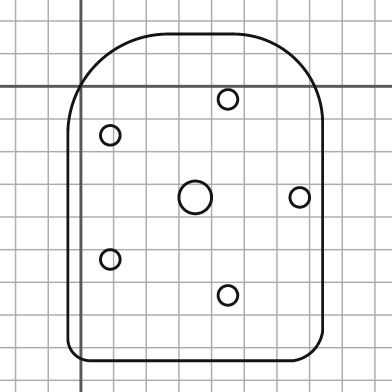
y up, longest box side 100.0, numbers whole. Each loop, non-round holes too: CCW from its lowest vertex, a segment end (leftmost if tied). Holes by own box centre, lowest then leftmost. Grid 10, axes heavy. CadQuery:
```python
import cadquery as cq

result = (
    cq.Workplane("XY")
    .moveTo(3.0, -84.0)
    .lineTo(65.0, -84.0)
    .threePointArc((71.0, -81.0), (74.0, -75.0))
    .lineTo(74.0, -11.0)
    .threePointArc((66.0, 8.0), (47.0, 16.0))
    .lineTo(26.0, 16.0)
    .threePointArc((5.0, 7.0), (-4.0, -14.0))
    .lineTo(-4.0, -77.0)
    .threePointArc((-2.0, -82.0), (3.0, -84.0))
    .close()
    .moveTo(45.0, -64.0)
    .circle(3.0)
    .moveTo(9.0, -53.0)
    .circle(3.0)
    .moveTo(35.0, -34.0)
    .circle(5.0)
    .moveTo(67.0, -34.0)
    .circle(3.0)
    .moveTo(9.0, -15.0)
    .circle(3.0)
    .moveTo(45.0, -4.0)
    .circle(3.0)
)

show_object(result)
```